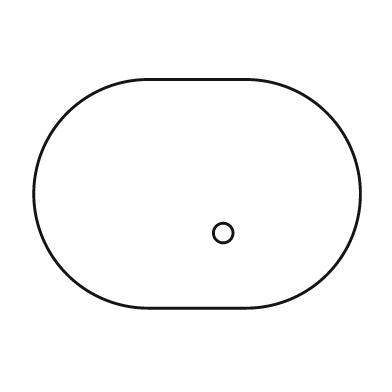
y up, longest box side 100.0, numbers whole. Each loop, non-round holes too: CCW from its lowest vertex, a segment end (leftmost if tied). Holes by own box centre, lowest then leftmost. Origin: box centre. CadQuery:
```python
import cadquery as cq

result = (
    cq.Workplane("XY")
    .moveTo(-15.0, -35.0)
    .lineTo(15.0, -35.0)
    .threePointArc((50.0, 0.0), (15.0, 35.0))
    .lineTo(-15.0, 35.0)
    .threePointArc((-50.0, 0.0), (-15.0, -35.0))
    .close()
    .moveTo(8.0, -12.0)
    .circle(3.0)
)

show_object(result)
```